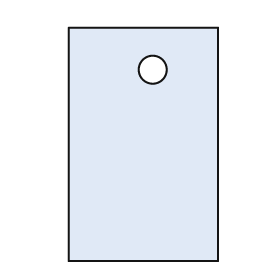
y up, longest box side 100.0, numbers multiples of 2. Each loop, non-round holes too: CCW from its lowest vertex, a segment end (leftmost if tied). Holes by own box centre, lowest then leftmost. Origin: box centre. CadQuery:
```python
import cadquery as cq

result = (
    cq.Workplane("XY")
    .moveTo(-32.0, -50.0)
    .lineTo(32.0, -50.0)
    .lineTo(32.0, 50.0)
    .lineTo(-32.0, 50.0)
    .close()
    .moveTo(4.0, 32.0)
    .circle(6.0)
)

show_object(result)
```